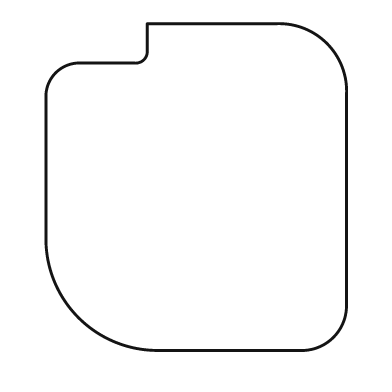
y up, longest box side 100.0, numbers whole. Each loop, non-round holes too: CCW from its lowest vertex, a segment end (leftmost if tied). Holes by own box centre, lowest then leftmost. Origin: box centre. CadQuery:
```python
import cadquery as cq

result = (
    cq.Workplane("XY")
    .moveTo(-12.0, -50.0)
    .lineTo(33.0, -50.0)
    .threePointArc((42.0, -46.0), (46.0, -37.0))
    .lineTo(46.0, 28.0)
    .threePointArc((40.0, 44.0), (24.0, 50.0))
    .lineTo(-15.0, 50.0)
    .lineTo(-15.0, 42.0)
    .threePointArc((-16.0, 39.0), (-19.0, 38.0))
    .lineTo(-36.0, 38.0)
    .threePointArc((-43.0, 35.0), (-46.0, 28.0))
    .lineTo(-46.0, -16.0)
    .threePointArc((-36.0, -40.0), (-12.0, -50.0))
    .close()
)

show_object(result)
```